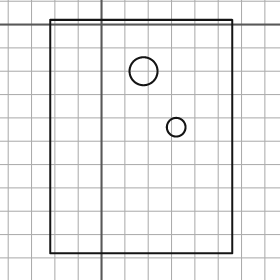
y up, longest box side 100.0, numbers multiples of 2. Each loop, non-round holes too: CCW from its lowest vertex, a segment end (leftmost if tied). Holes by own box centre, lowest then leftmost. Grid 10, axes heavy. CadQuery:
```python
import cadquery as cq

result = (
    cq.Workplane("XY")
    .moveTo(-22.0, -98.0)
    .lineTo(56.0, -98.0)
    .lineTo(56.0, 2.0)
    .lineTo(-22.0, 2.0)
    .close()
    .moveTo(32.0, -44.0)
    .circle(4.0)
    .moveTo(18.0, -20.0)
    .circle(6.0)
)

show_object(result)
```